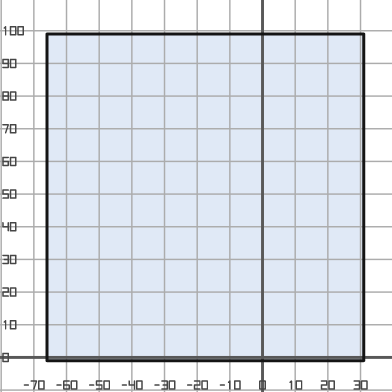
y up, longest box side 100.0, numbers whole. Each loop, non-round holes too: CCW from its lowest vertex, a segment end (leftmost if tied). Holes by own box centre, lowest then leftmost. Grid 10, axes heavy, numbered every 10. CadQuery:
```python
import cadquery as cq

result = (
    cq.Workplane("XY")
    .moveTo(-66.0, -1.0)
    .lineTo(31.0, -1.0)
    .lineTo(31.0, 99.0)
    .lineTo(-66.0, 99.0)
    .close()
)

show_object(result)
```